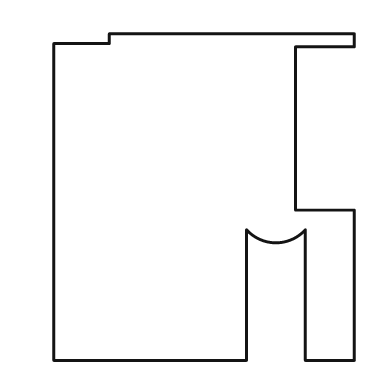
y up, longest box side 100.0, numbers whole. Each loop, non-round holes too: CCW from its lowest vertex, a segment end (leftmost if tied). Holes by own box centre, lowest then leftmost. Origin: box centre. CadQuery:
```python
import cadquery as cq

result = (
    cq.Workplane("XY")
    .moveTo(-46.0, -50.0)
    .lineTo(13.0, -50.0)
    .lineTo(13.0, -10.0)
    .threePointArc((22.0, -14.0), (31.0, -10.0))
    .lineTo(31.0, -50.0)
    .lineTo(46.0, -50.0)
    .lineTo(46.0, -4.0)
    .lineTo(28.0, -4.0)
    .lineTo(28.0, 46.0)
    .lineTo(46.0, 46.0)
    .lineTo(46.0, 50.0)
    .lineTo(-29.0, 50.0)
    .lineTo(-29.0, 47.0)
    .lineTo(-46.0, 47.0)
    .close()
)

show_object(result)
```